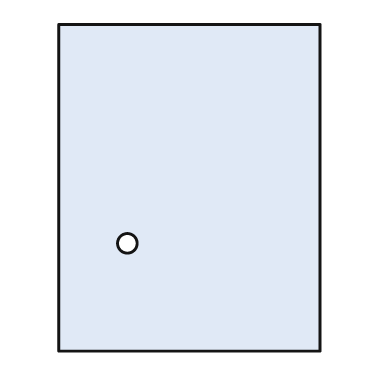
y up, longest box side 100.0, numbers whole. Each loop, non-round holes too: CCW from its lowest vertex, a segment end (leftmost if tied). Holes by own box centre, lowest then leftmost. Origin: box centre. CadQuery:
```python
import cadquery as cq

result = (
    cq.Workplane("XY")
    .moveTo(-40.0, -50.0)
    .lineTo(40.0, -50.0)
    .lineTo(40.0, 50.0)
    .lineTo(-40.0, 50.0)
    .close()
    .moveTo(-19.0, -17.0)
    .circle(3.0)
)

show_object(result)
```